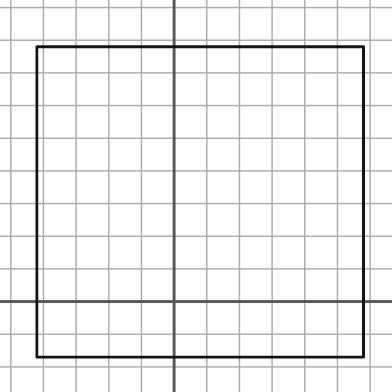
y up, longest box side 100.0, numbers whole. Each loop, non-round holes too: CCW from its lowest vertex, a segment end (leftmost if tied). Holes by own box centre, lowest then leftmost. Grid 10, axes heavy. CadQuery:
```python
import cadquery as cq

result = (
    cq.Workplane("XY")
    .moveTo(-42.0, -17.0)
    .lineTo(58.0, -17.0)
    .lineTo(58.0, 78.0)
    .lineTo(-42.0, 78.0)
    .close()
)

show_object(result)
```